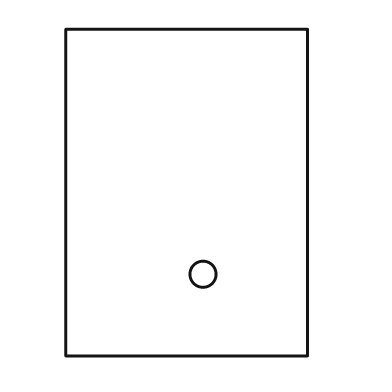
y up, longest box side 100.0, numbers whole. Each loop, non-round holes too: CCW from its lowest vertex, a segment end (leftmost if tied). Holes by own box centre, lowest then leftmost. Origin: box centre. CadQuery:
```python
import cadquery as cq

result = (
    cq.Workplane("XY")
    .moveTo(-37.0, -50.0)
    .lineTo(37.0, -50.0)
    .lineTo(37.0, 50.0)
    .lineTo(-37.0, 50.0)
    .close()
    .moveTo(5.0, -25.0)
    .circle(4.0)
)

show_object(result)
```